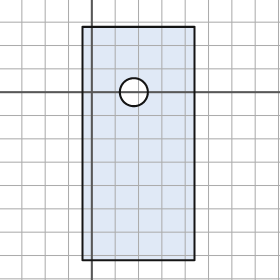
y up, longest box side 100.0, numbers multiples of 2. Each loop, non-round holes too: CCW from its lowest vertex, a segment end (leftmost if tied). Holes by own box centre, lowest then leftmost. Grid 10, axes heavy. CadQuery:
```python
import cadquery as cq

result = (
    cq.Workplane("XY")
    .moveTo(-4.0, -72.0)
    .lineTo(44.0, -72.0)
    .lineTo(44.0, 28.0)
    .lineTo(-4.0, 28.0)
    .close()
    .moveTo(18.0, 0.0)
    .circle(6.0)
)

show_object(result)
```